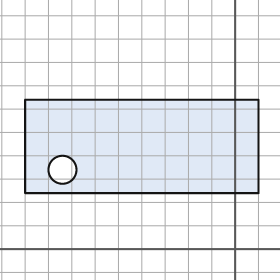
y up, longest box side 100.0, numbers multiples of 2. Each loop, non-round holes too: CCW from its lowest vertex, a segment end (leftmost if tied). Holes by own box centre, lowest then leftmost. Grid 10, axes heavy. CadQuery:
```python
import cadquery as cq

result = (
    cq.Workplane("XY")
    .moveTo(-90.0, 24.0)
    .lineTo(10.0, 24.0)
    .lineTo(10.0, 64.0)
    .lineTo(-90.0, 64.0)
    .close()
    .moveTo(-74.0, 34.0)
    .circle(6.0)
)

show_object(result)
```